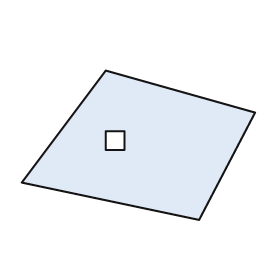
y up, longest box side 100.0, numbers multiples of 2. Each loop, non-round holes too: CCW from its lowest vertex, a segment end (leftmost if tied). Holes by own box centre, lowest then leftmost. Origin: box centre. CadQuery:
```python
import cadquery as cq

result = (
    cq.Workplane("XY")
    .moveTo(26.0, -32.0)
    .lineTo(50.0, 14.0)
    .lineTo(-14.0, 32.0)
    .lineTo(-50.0, -16.0)
    .close()
    .moveTo(-14.0, -2.0)
    .lineTo(-6.0, -2.0)
    .lineTo(-6.0, 6.0)
    .lineTo(-14.0, 6.0)
    .close()
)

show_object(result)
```